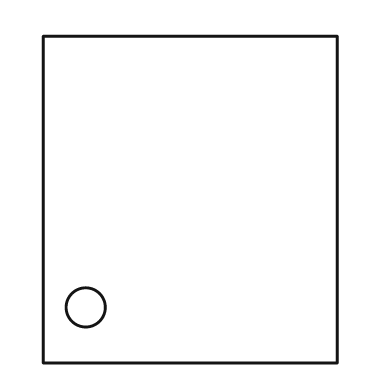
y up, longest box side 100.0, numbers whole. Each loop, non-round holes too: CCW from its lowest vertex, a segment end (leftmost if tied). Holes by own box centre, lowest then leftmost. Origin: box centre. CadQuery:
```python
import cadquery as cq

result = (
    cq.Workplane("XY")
    .moveTo(-45.0, -50.0)
    .lineTo(45.0, -50.0)
    .lineTo(45.0, 50.0)
    .lineTo(-45.0, 50.0)
    .close()
    .moveTo(-32.0, -33.0)
    .circle(6.0)
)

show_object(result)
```